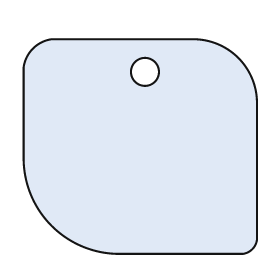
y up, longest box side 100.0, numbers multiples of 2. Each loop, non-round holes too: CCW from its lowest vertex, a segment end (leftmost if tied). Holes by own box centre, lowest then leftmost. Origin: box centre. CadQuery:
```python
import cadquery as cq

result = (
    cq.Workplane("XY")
    .moveTo(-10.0, -46.0)
    .lineTo(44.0, -46.0)
    .threePointArc((48.0, -44.0), (50.0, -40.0))
    .lineTo(50.0, 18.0)
    .threePointArc((42.0, 38.0), (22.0, 46.0))
    .lineTo(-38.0, 46.0)
    .threePointArc((-46.0, 42.0), (-50.0, 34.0))
    .lineTo(-50.0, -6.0)
    .threePointArc((-38.0, -34.0), (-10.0, -46.0))
    .close()
    .moveTo(2.0, 32.0)
    .circle(6.0)
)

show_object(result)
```